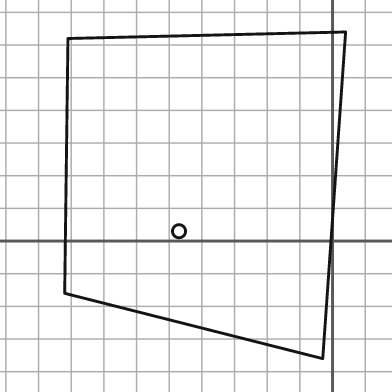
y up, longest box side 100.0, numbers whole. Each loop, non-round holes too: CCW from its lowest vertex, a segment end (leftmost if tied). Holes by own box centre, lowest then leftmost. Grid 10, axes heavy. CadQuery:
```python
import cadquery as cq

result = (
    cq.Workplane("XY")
    .moveTo(-3.0, -36.0)
    .lineTo(4.0, 64.0)
    .lineTo(-81.0, 62.0)
    .lineTo(-82.0, -16.0)
    .close()
    .moveTo(-47.0, 3.0)
    .circle(2.0)
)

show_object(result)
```